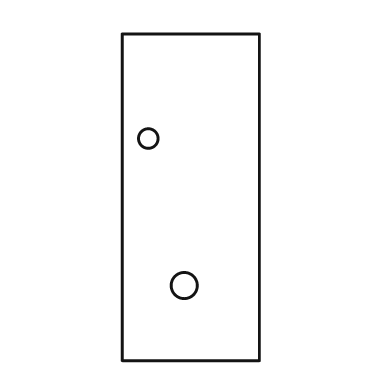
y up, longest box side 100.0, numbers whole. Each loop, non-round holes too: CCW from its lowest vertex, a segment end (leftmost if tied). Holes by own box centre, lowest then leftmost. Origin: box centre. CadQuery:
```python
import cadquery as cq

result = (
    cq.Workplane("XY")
    .moveTo(-21.0, -50.0)
    .lineTo(21.0, -50.0)
    .lineTo(21.0, 50.0)
    .lineTo(-21.0, 50.0)
    .close()
    .moveTo(-2.0, -27.0)
    .circle(4.0)
    .moveTo(-13.0, 18.0)
    .circle(3.0)
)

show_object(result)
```